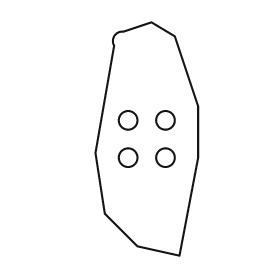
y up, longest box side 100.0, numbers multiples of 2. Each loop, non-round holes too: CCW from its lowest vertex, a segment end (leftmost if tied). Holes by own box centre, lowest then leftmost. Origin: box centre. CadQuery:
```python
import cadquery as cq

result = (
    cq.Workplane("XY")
    .moveTo(14.0, -50.0)
    .lineTo(22.0, -8.0)
    .lineTo(22.0, 14.0)
    .lineTo(12.0, 44.0)
    .lineTo(2.0, 50.0)
    .lineTo(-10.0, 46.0)
    .threePointArc((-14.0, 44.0), (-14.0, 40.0))
    .lineTo(-22.0, -6.0)
    .lineTo(-18.0, -32.0)
    .lineTo(-4.0, -46.0)
    .close()
    .moveTo(-8.0, -8.0)
    .circle(4.0)
    .moveTo(8.0, -8.0)
    .circle(4.0)
    .moveTo(-8.0, 8.0)
    .circle(4.0)
    .moveTo(8.0, 8.0)
    .circle(4.0)
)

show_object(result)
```